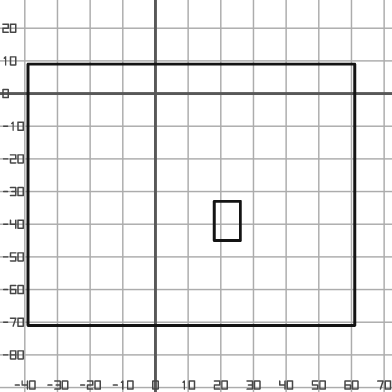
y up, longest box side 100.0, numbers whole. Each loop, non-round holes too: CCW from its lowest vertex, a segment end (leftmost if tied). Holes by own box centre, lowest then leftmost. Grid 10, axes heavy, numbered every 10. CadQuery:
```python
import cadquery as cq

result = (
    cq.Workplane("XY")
    .moveTo(-39.0, -71.0)
    .lineTo(61.0, -71.0)
    .lineTo(61.0, 9.0)
    .lineTo(-39.0, 9.0)
    .close()
    .moveTo(18.0, -45.0)
    .lineTo(26.0, -45.0)
    .lineTo(26.0, -33.0)
    .lineTo(18.0, -33.0)
    .close()
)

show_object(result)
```